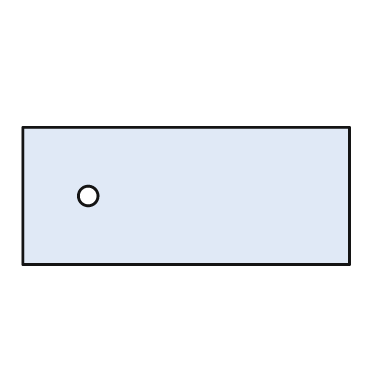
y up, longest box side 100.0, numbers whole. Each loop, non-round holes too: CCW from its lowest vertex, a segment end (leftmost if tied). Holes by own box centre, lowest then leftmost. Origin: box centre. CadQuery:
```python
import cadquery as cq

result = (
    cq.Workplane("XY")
    .moveTo(-50.0, -21.0)
    .lineTo(50.0, -21.0)
    .lineTo(50.0, 21.0)
    .lineTo(-50.0, 21.0)
    .close()
    .moveTo(-30.0, 0.0)
    .circle(3.0)
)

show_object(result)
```